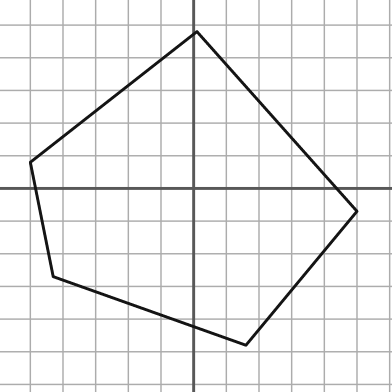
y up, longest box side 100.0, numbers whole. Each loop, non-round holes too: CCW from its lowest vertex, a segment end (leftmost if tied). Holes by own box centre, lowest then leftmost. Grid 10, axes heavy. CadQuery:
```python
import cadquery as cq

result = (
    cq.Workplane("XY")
    .moveTo(16.0, -48.0)
    .lineTo(50.0, -7.0)
    .lineTo(1.0, 48.0)
    .lineTo(-50.0, 8.0)
    .lineTo(-43.0, -27.0)
    .close()
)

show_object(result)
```